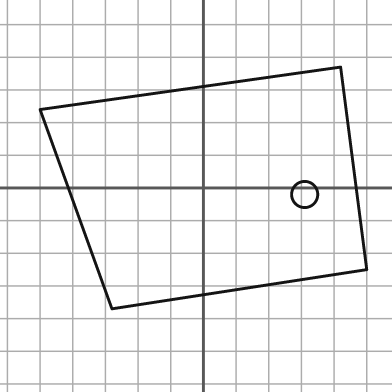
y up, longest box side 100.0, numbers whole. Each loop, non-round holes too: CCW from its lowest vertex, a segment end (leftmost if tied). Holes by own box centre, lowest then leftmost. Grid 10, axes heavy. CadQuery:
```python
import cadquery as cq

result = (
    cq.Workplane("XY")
    .moveTo(-28.0, -37.0)
    .lineTo(50.0, -25.0)
    .lineTo(42.0, 37.0)
    .lineTo(-50.0, 24.0)
    .close()
    .moveTo(31.0, -2.0)
    .circle(4.0)
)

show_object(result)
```